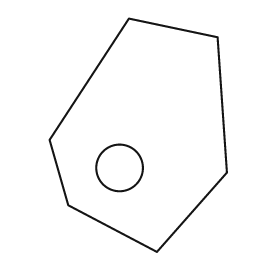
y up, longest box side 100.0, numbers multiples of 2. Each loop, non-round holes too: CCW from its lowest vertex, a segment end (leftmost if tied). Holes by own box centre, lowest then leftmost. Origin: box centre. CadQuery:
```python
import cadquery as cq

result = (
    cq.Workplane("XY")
    .moveTo(8.0, -50.0)
    .lineTo(38.0, -16.0)
    .lineTo(34.0, 42.0)
    .lineTo(-4.0, 50.0)
    .lineTo(-38.0, -2.0)
    .lineTo(-30.0, -30.0)
    .close()
    .moveTo(-8.0, -14.0)
    .circle(10.0)
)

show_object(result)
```